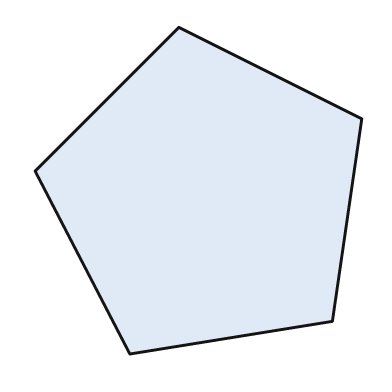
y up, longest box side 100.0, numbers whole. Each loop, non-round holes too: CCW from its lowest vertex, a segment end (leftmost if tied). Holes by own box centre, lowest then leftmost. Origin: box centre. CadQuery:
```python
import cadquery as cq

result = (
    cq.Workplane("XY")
    .moveTo(-21.0, -50.0)
    .lineTo(41.0, -40.0)
    .lineTo(50.0, 22.0)
    .lineTo(-6.0, 50.0)
    .lineTo(-50.0, 6.0)
    .close()
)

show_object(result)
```